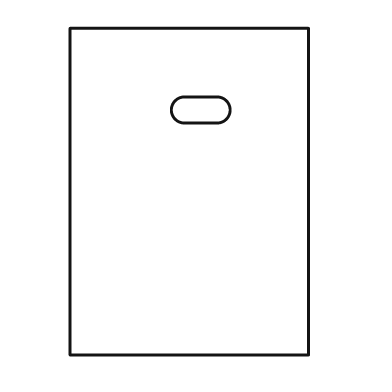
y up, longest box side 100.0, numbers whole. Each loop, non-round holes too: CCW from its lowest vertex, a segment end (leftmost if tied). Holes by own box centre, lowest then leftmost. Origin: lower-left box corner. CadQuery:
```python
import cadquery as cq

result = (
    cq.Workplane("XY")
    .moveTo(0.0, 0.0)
    .lineTo(73.0, 0.0)
    .lineTo(73.0, 100.0)
    .lineTo(0.0, 100.0)
    .close()
    .moveTo(35.0, 71.0)
    .lineTo(45.0, 71.0)
    .threePointArc((49.0, 75.0), (45.0, 79.0))
    .lineTo(35.0, 79.0)
    .threePointArc((31.0, 75.0), (35.0, 71.0))
    .close()
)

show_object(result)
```